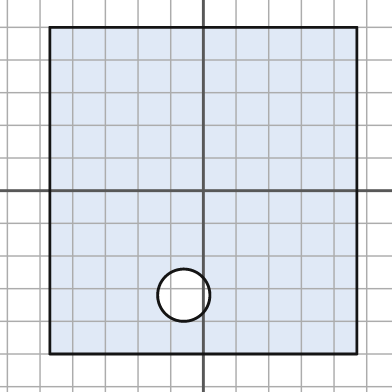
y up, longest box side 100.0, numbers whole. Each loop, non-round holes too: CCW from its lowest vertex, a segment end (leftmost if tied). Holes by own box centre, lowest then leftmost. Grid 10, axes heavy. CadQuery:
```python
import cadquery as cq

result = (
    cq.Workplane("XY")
    .moveTo(-47.0, -50.0)
    .lineTo(47.0, -50.0)
    .lineTo(47.0, 50.0)
    .lineTo(-47.0, 50.0)
    .close()
    .moveTo(-6.0, -32.0)
    .circle(8.0)
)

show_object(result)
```